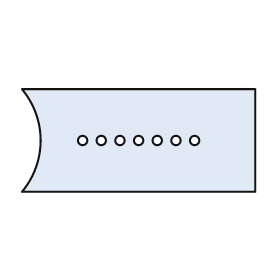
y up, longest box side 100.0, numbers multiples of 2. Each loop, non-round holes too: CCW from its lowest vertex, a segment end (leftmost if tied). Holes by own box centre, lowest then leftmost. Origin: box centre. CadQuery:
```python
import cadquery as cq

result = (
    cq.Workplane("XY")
    .moveTo(-50.0, -22.0)
    .lineTo(50.0, -22.0)
    .lineTo(50.0, 22.0)
    .lineTo(-50.0, 22.0)
    .threePointArc((-42.0, 0.0), (-50.0, -22.0))
    .close()
    .moveTo(-24.0, 0.0)
    .circle(2.0)
    .moveTo(-16.0, 0.0)
    .circle(2.0)
    .moveTo(-8.0, 0.0)
    .circle(2.0)
    .moveTo(0.0, 0.0)
    .circle(2.0)
    .moveTo(8.0, 0.0)
    .circle(2.0)
    .moveTo(16.0, 0.0)
    .circle(2.0)
    .moveTo(24.0, 0.0)
    .circle(2.0)
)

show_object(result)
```